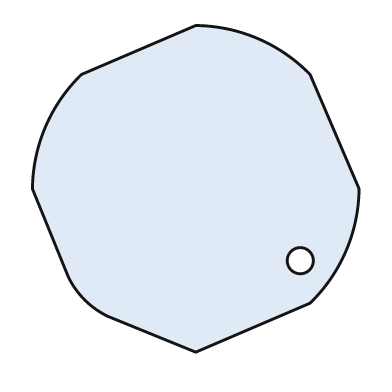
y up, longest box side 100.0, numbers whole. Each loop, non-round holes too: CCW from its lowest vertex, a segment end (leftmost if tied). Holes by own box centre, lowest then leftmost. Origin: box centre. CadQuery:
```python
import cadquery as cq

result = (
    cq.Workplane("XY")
    .moveTo(0.0, -50.0)
    .lineTo(35.0, -35.0)
    .threePointArc((46.0, -19.0), (50.0, 0.0))
    .lineTo(35.0, 35.0)
    .threePointArc((19.0, 46.0), (0.0, 50.0))
    .lineTo(-35.0, 35.0)
    .threePointArc((-46.0, 19.0), (-50.0, 0.0))
    .lineTo(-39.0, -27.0)
    .threePointArc((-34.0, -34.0), (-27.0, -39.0))
    .close()
    .moveTo(32.0, -22.0)
    .circle(4.0)
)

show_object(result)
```